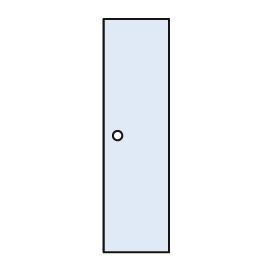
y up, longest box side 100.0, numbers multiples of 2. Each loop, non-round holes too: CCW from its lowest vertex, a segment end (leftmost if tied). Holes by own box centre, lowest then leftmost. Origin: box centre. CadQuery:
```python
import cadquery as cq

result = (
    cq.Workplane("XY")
    .moveTo(-14.0, -50.0)
    .lineTo(14.0, -50.0)
    .lineTo(14.0, 50.0)
    .lineTo(-14.0, 50.0)
    .close()
    .moveTo(-8.0, 0.0)
    .circle(2.0)
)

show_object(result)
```